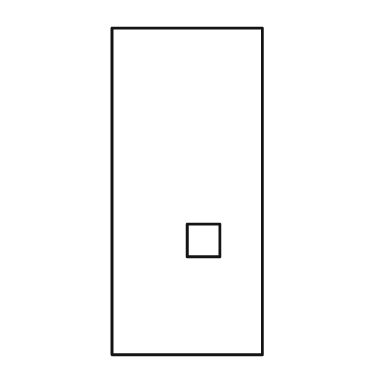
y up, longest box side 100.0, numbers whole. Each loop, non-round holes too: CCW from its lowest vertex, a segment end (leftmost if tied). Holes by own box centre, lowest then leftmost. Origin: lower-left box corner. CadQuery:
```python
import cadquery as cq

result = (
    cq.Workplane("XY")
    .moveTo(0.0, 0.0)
    .lineTo(46.0, 0.0)
    .lineTo(46.0, 100.0)
    .lineTo(0.0, 100.0)
    .close()
    .moveTo(23.0, 30.0)
    .lineTo(33.0, 30.0)
    .lineTo(33.0, 40.0)
    .lineTo(23.0, 40.0)
    .close()
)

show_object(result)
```